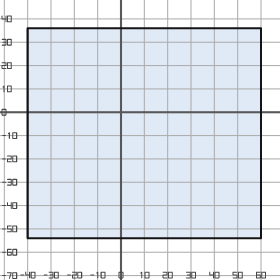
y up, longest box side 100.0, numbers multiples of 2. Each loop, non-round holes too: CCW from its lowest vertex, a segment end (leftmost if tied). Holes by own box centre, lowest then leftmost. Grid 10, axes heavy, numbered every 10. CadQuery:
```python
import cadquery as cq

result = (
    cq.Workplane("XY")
    .moveTo(-40.0, -54.0)
    .lineTo(60.0, -54.0)
    .lineTo(60.0, 36.0)
    .lineTo(-40.0, 36.0)
    .close()
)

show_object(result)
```